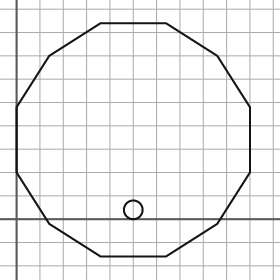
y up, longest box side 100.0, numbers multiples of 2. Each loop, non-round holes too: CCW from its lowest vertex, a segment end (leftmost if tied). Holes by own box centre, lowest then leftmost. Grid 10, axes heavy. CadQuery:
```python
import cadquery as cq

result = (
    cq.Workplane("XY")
    .moveTo(36.0, -16.0)
    .lineTo(64.0, -16.0)
    .lineTo(86.0, -2.0)
    .lineTo(100.0, 20.0)
    .lineTo(100.0, 48.0)
    .lineTo(86.0, 70.0)
    .lineTo(64.0, 84.0)
    .lineTo(36.0, 84.0)
    .lineTo(14.0, 70.0)
    .lineTo(0.0, 48.0)
    .lineTo(0.0, 20.0)
    .lineTo(14.0, -2.0)
    .close()
    .moveTo(50.0, 4.0)
    .circle(4.0)
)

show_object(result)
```